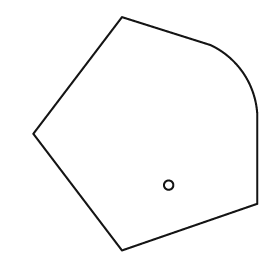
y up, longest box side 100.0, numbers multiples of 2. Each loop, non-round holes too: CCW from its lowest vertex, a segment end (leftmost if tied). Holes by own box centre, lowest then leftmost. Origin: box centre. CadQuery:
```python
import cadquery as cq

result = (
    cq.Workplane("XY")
    .moveTo(-10.0, -50.0)
    .lineTo(48.0, -30.0)
    .lineTo(48.0, 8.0)
    .threePointArc((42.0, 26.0), (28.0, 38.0))
    .lineTo(-10.0, 50.0)
    .lineTo(-48.0, 0.0)
    .close()
    .moveTo(10.0, -22.0)
    .circle(2.0)
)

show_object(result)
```